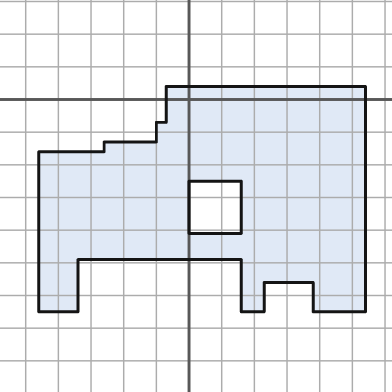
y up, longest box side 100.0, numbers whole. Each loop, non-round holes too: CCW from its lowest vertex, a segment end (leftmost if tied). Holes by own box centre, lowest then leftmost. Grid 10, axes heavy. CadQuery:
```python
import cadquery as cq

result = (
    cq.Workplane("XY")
    .moveTo(-46.0, -65.0)
    .lineTo(-34.0, -65.0)
    .lineTo(-34.0, -49.0)
    .lineTo(16.0, -49.0)
    .lineTo(16.0, -65.0)
    .lineTo(23.0, -65.0)
    .lineTo(23.0, -56.0)
    .lineTo(38.0, -56.0)
    .lineTo(38.0, -65.0)
    .lineTo(54.0, -65.0)
    .lineTo(54.0, 4.0)
    .lineTo(-7.0, 4.0)
    .lineTo(-7.0, -7.0)
    .lineTo(-10.0, -7.0)
    .lineTo(-10.0, -13.0)
    .lineTo(-26.0, -13.0)
    .lineTo(-26.0, -16.0)
    .lineTo(-46.0, -16.0)
    .close()
    .moveTo(0.0, -41.0)
    .lineTo(16.0, -41.0)
    .lineTo(16.0, -25.0)
    .lineTo(0.0, -25.0)
    .close()
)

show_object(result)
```